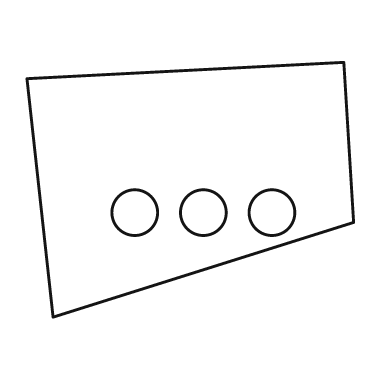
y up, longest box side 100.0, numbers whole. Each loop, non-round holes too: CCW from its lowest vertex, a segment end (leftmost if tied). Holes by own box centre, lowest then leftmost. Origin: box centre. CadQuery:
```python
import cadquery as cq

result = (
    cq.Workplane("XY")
    .moveTo(-42.0, -39.0)
    .lineTo(50.0, -10.0)
    .lineTo(47.0, 39.0)
    .lineTo(-50.0, 34.0)
    .close()
    .moveTo(-17.0, -7.0)
    .circle(7.0)
    .moveTo(4.0, -7.0)
    .circle(7.0)
    .moveTo(25.0, -7.0)
    .circle(7.0)
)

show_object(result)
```